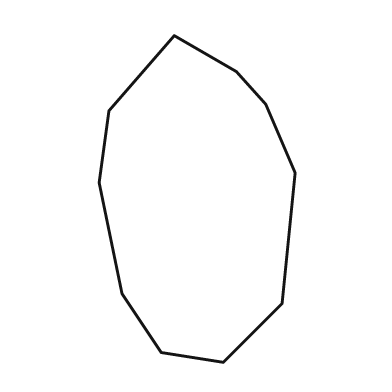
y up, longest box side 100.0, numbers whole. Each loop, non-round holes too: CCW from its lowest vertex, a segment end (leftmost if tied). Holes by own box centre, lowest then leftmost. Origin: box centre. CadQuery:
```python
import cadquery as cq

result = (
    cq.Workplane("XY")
    .moveTo(8.0, -50.0)
    .lineTo(26.0, -32.0)
    .lineTo(30.0, 8.0)
    .lineTo(21.0, 29.0)
    .lineTo(12.0, 39.0)
    .lineTo(-7.0, 50.0)
    .lineTo(-27.0, 27.0)
    .lineTo(-30.0, 5.0)
    .lineTo(-23.0, -29.0)
    .lineTo(-11.0, -47.0)
    .close()
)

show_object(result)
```